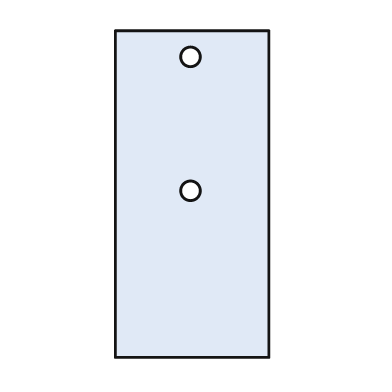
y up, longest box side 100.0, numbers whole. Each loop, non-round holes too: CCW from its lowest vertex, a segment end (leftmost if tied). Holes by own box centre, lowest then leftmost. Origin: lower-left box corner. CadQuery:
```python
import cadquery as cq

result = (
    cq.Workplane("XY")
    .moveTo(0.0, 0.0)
    .lineTo(47.0, 0.0)
    .lineTo(47.0, 100.0)
    .lineTo(0.0, 100.0)
    .close()
    .moveTo(23.0, 51.0)
    .circle(3.0)
    .moveTo(23.0, 92.0)
    .circle(3.0)
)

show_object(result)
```